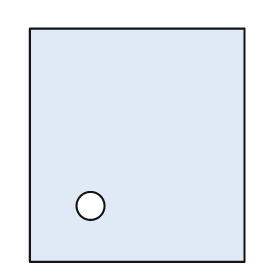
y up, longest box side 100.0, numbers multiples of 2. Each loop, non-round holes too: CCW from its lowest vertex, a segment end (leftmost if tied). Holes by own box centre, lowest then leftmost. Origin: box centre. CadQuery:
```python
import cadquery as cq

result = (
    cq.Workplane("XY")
    .moveTo(-46.0, -50.0)
    .lineTo(46.0, -50.0)
    .lineTo(46.0, 50.0)
    .lineTo(-46.0, 50.0)
    .close()
    .moveTo(-20.0, -26.0)
    .circle(6.0)
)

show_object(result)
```